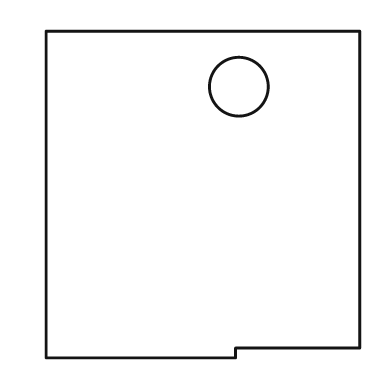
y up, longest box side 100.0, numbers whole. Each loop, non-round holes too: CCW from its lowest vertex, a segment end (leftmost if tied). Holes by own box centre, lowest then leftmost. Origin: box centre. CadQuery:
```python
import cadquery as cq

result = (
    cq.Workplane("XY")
    .moveTo(-48.0, -50.0)
    .lineTo(10.0, -50.0)
    .lineTo(10.0, -47.0)
    .lineTo(48.0, -47.0)
    .lineTo(48.0, 50.0)
    .lineTo(-48.0, 50.0)
    .close()
    .moveTo(11.0, 33.0)
    .circle(9.0)
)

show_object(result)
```